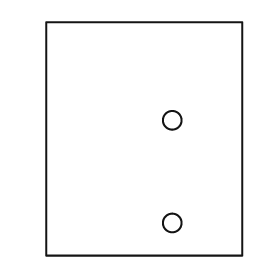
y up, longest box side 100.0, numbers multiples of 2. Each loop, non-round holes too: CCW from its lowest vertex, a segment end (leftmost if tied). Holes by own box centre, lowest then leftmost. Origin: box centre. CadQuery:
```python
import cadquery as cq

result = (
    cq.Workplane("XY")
    .moveTo(-42.0, -50.0)
    .lineTo(42.0, -50.0)
    .lineTo(42.0, 50.0)
    .lineTo(-42.0, 50.0)
    .close()
    .moveTo(12.0, -36.0)
    .circle(4.0)
    .moveTo(12.0, 8.0)
    .circle(4.0)
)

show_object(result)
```